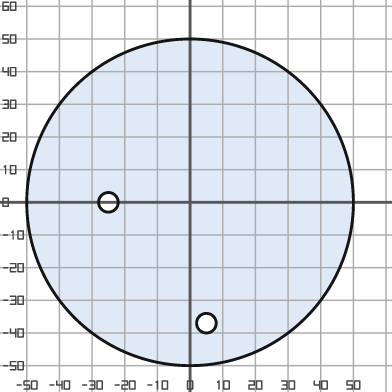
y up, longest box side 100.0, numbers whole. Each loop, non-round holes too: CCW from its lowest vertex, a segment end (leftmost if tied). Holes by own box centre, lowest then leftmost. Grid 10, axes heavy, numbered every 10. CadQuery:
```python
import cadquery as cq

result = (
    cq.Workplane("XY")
    .moveTo(0.0, 0.0)
    .circle(50.0)
    .moveTo(5.0, -37.0)
    .circle(3.0)
    .moveTo(-25.0, 0.0)
    .circle(3.0)
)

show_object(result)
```